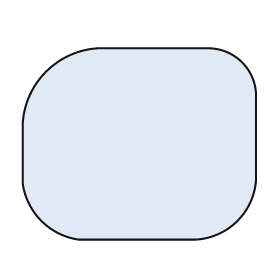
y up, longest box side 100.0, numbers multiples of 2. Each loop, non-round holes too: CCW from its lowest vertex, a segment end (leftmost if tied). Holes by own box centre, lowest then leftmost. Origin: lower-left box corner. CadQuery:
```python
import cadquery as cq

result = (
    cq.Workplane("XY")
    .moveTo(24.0, 0.0)
    .lineTo(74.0, 0.0)
    .threePointArc((92.0, 8.0), (100.0, 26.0))
    .lineTo(100.0, 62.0)
    .threePointArc((94.0, 76.0), (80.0, 82.0))
    .lineTo(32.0, 82.0)
    .threePointArc((10.0, 72.0), (0.0, 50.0))
    .lineTo(0.0, 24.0)
    .threePointArc((8.0, 8.0), (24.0, 0.0))
    .close()
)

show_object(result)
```